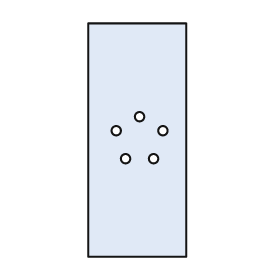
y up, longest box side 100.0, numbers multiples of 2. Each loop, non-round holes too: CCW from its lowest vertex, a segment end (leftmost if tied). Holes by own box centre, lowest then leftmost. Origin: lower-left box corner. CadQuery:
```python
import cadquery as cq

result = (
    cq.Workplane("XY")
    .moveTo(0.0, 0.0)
    .lineTo(42.0, 0.0)
    .lineTo(42.0, 100.0)
    .lineTo(0.0, 100.0)
    .close()
    .moveTo(16.0, 42.0)
    .circle(2.0)
    .moveTo(28.0, 42.0)
    .circle(2.0)
    .moveTo(12.0, 54.0)
    .circle(2.0)
    .moveTo(32.0, 54.0)
    .circle(2.0)
    .moveTo(22.0, 60.0)
    .circle(2.0)
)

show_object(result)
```